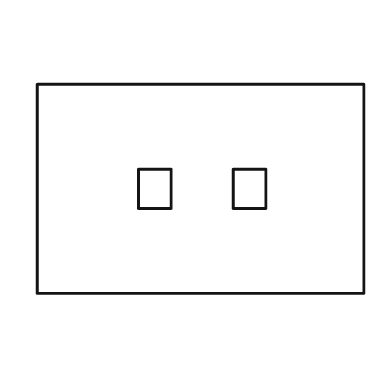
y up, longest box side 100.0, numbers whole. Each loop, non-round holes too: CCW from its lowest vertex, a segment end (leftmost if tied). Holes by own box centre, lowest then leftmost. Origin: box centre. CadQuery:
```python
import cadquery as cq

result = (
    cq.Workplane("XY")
    .moveTo(-50.0, -32.0)
    .lineTo(50.0, -32.0)
    .lineTo(50.0, 32.0)
    .lineTo(-50.0, 32.0)
    .close()
    .moveTo(-19.0, -6.0)
    .lineTo(-9.0, -6.0)
    .lineTo(-9.0, 6.0)
    .lineTo(-19.0, 6.0)
    .close()
    .moveTo(10.0, -6.0)
    .lineTo(20.0, -6.0)
    .lineTo(20.0, 6.0)
    .lineTo(10.0, 6.0)
    .close()
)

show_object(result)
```